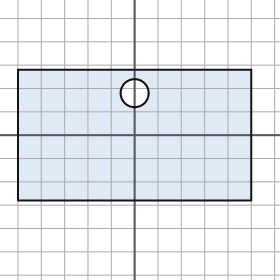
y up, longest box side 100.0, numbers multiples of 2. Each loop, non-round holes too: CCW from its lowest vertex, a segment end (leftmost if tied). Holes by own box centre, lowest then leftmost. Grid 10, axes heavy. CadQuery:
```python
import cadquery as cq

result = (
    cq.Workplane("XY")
    .moveTo(-50.0, -28.0)
    .lineTo(50.0, -28.0)
    .lineTo(50.0, 28.0)
    .lineTo(-50.0, 28.0)
    .close()
    .moveTo(0.0, 18.0)
    .circle(6.0)
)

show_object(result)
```